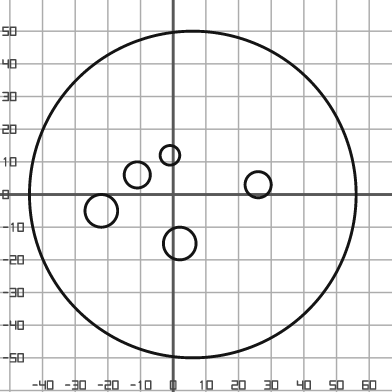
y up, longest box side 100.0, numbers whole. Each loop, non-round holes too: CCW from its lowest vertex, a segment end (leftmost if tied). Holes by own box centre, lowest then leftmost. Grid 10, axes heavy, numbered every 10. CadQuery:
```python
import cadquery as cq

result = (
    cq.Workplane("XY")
    .moveTo(6.0, 0.0)
    .circle(50.0)
    .moveTo(2.0, -15.0)
    .circle(5.0)
    .moveTo(-22.0, -5.0)
    .circle(5.0)
    .moveTo(26.0, 3.0)
    .circle(4.0)
    .moveTo(-11.0, 6.0)
    .circle(4.0)
    .moveTo(-1.0, 12.0)
    .circle(3.0)
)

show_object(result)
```